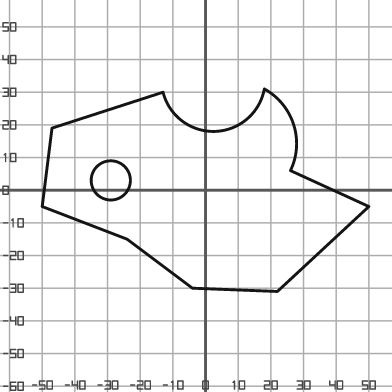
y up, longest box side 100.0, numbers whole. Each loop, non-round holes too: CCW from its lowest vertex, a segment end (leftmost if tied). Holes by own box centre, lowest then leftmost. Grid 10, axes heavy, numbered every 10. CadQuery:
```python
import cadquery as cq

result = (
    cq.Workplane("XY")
    .moveTo(22.0, -31.0)
    .lineTo(50.0, -5.0)
    .lineTo(26.0, 6.0)
    .threePointArc((27.0, 20.0), (18.0, 31.0))
    .threePointArc((3.0, 18.0), (-13.0, 30.0))
    .lineTo(-47.0, 19.0)
    .lineTo(-50.0, -5.0)
    .lineTo(-24.0, -15.0)
    .lineTo(-4.0, -30.0)
    .close()
    .moveTo(-29.0, 3.0)
    .circle(6.0)
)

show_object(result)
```